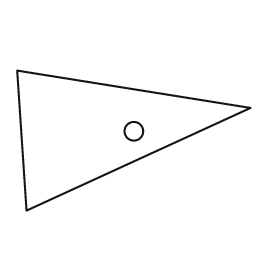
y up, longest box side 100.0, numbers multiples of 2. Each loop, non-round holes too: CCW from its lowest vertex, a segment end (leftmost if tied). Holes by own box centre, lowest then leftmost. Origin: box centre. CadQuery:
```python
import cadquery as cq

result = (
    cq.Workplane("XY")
    .moveTo(-46.0, -30.0)
    .lineTo(50.0, 14.0)
    .lineTo(-50.0, 30.0)
    .close()
    .moveTo(0.0, 4.0)
    .circle(4.0)
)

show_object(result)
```